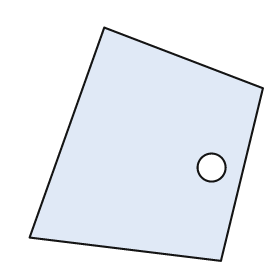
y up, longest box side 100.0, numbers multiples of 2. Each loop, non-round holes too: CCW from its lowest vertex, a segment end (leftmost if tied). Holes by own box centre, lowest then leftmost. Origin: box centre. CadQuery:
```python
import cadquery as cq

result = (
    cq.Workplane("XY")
    .moveTo(32.0, -50.0)
    .lineTo(50.0, 24.0)
    .lineTo(-18.0, 50.0)
    .lineTo(-50.0, -40.0)
    .close()
    .moveTo(28.0, -10.0)
    .circle(6.0)
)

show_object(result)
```